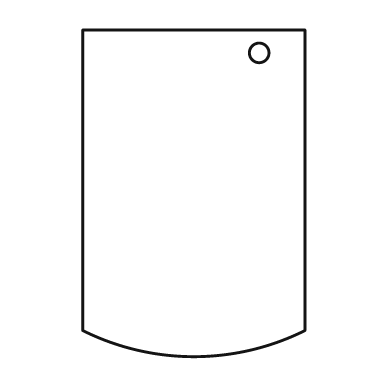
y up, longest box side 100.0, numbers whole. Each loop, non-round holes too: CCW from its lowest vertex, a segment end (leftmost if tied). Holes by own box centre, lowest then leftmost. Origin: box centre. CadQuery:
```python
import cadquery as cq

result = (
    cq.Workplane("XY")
    .moveTo(-34.0, -42.0)
    .threePointArc((0.0, -50.0), (34.0, -42.0))
    .lineTo(34.0, 50.0)
    .lineTo(-34.0, 50.0)
    .close()
    .moveTo(20.0, 43.0)
    .circle(3.0)
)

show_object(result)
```